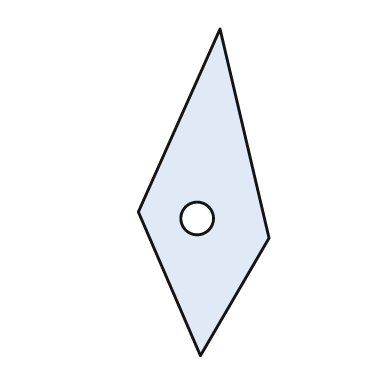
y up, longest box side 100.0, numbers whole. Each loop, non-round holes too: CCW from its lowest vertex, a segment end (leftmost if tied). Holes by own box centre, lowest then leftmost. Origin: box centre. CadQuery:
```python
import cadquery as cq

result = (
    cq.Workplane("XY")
    .moveTo(-1.0, -50.0)
    .lineTo(20.0, -14.0)
    .lineTo(5.0, 50.0)
    .lineTo(-20.0, -6.0)
    .close()
    .moveTo(-2.0, -8.0)
    .circle(5.0)
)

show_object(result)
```